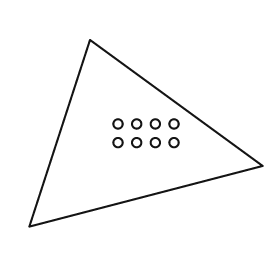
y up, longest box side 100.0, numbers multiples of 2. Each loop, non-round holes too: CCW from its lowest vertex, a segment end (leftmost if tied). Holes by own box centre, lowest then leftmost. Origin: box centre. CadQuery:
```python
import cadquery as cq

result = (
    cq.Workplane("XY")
    .moveTo(-50.0, -40.0)
    .lineTo(50.0, -14.0)
    .lineTo(-24.0, 40.0)
    .close()
    .moveTo(-12.0, -4.0)
    .circle(2.0)
    .moveTo(-4.0, -4.0)
    .circle(2.0)
    .moveTo(4.0, -4.0)
    .circle(2.0)
    .moveTo(12.0, -4.0)
    .circle(2.0)
    .moveTo(-12.0, 4.0)
    .circle(2.0)
    .moveTo(-4.0, 4.0)
    .circle(2.0)
    .moveTo(4.0, 4.0)
    .circle(2.0)
    .moveTo(12.0, 4.0)
    .circle(2.0)
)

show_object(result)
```